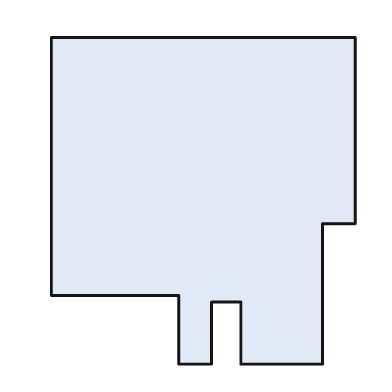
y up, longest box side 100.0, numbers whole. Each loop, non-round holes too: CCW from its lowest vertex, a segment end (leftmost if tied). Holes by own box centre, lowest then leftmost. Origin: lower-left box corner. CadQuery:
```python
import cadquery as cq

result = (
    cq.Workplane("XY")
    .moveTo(39.0, 0.0)
    .lineTo(49.0, 0.0)
    .lineTo(49.0, 19.0)
    .lineTo(58.0, 19.0)
    .lineTo(58.0, 0.0)
    .lineTo(83.0, 0.0)
    .lineTo(83.0, 43.0)
    .lineTo(93.0, 43.0)
    .lineTo(93.0, 100.0)
    .lineTo(0.0, 100.0)
    .lineTo(0.0, 21.0)
    .lineTo(39.0, 21.0)
    .close()
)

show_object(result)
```